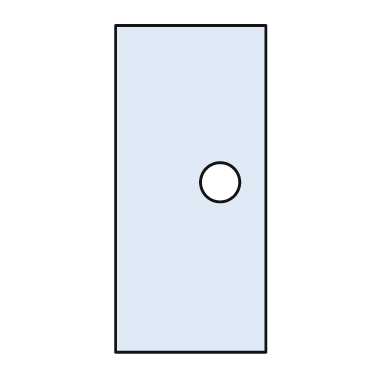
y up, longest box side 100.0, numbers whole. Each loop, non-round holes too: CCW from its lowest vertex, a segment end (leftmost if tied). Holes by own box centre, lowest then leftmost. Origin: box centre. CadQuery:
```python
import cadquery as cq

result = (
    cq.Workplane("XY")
    .moveTo(-23.0, -50.0)
    .lineTo(23.0, -50.0)
    .lineTo(23.0, 50.0)
    .lineTo(-23.0, 50.0)
    .close()
    .moveTo(9.0, 2.0)
    .circle(6.0)
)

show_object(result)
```